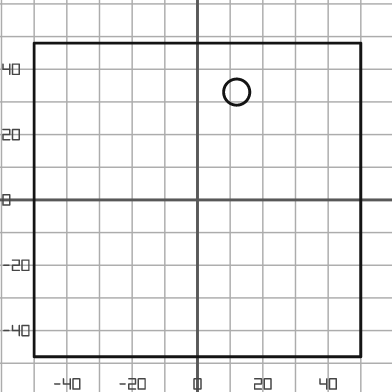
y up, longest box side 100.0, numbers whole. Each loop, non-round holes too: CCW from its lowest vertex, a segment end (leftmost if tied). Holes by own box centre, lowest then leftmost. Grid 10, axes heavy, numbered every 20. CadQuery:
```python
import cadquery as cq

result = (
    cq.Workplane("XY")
    .moveTo(-50.0, -48.0)
    .lineTo(50.0, -48.0)
    .lineTo(50.0, 48.0)
    .lineTo(-50.0, 48.0)
    .close()
    .moveTo(12.0, 33.0)
    .circle(4.0)
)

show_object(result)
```